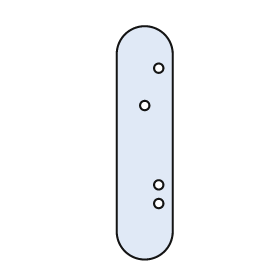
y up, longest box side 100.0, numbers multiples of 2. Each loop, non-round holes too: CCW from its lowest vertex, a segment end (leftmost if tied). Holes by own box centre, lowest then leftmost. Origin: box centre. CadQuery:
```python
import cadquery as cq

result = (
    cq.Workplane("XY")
    .moveTo(-12.0, -38.0)
    .threePointArc((0.0, -50.0), (12.0, -38.0))
    .lineTo(12.0, 38.0)
    .threePointArc((0.0, 50.0), (-12.0, 38.0))
    .close()
    .moveTo(6.0, -26.0)
    .circle(2.0)
    .moveTo(6.0, -18.0)
    .circle(2.0)
    .moveTo(0.0, 16.0)
    .circle(2.0)
    .moveTo(6.0, 32.0)
    .circle(2.0)
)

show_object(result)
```